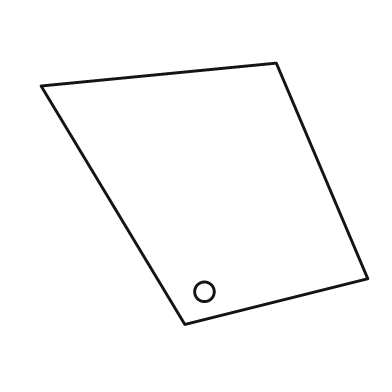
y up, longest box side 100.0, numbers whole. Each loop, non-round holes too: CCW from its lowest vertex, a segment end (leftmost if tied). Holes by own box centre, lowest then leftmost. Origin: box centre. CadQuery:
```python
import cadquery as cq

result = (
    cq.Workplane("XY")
    .moveTo(-6.0, -40.0)
    .lineTo(50.0, -26.0)
    .lineTo(22.0, 40.0)
    .lineTo(-50.0, 33.0)
    .close()
    .moveTo(0.0, -30.0)
    .circle(3.0)
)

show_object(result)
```